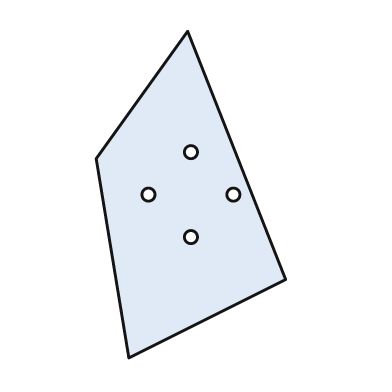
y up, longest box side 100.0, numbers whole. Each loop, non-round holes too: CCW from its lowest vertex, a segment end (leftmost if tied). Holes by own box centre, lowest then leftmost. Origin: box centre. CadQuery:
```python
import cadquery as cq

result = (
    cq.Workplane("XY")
    .moveTo(-19.0, -50.0)
    .lineTo(29.0, -26.0)
    .lineTo(-1.0, 50.0)
    .lineTo(-29.0, 11.0)
    .close()
    .moveTo(0.0, -13.0)
    .circle(2.0)
    .moveTo(-13.0, 0.0)
    .circle(2.0)
    .moveTo(13.0, 0.0)
    .circle(2.0)
    .moveTo(0.0, 13.0)
    .circle(2.0)
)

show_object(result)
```